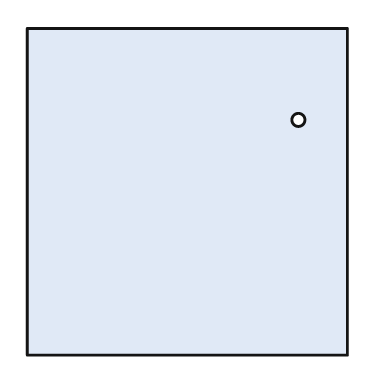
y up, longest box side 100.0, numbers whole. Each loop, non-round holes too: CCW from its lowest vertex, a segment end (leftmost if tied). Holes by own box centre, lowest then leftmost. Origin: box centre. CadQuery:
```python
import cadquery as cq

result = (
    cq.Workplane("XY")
    .moveTo(-49.0, -50.0)
    .lineTo(49.0, -50.0)
    .lineTo(49.0, 50.0)
    .lineTo(-49.0, 50.0)
    .close()
    .moveTo(34.0, 22.0)
    .circle(2.0)
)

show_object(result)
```